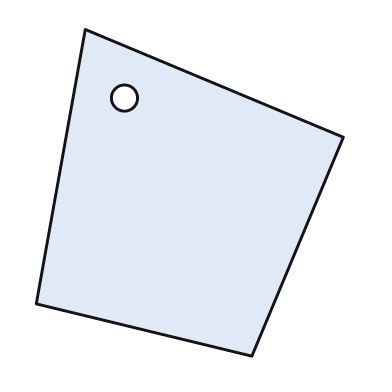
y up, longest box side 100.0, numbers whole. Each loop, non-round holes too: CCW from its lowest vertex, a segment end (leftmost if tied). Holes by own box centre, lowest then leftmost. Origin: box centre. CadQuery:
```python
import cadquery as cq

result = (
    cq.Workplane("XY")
    .moveTo(19.0, -50.0)
    .lineTo(47.0, 17.0)
    .lineTo(-32.0, 50.0)
    .lineTo(-47.0, -34.0)
    .close()
    .moveTo(-20.0, 29.0)
    .circle(4.0)
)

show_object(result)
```